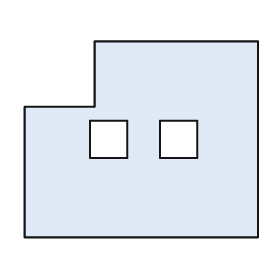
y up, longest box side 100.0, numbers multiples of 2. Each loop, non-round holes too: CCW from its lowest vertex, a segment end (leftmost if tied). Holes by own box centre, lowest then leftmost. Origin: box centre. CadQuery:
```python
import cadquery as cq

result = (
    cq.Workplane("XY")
    .moveTo(-50.0, -42.0)
    .lineTo(50.0, -42.0)
    .lineTo(50.0, 42.0)
    .lineTo(-20.0, 42.0)
    .lineTo(-20.0, 14.0)
    .lineTo(-50.0, 14.0)
    .close()
    .moveTo(-22.0, -8.0)
    .lineTo(-6.0, -8.0)
    .lineTo(-6.0, 8.0)
    .lineTo(-22.0, 8.0)
    .close()
    .moveTo(8.0, -8.0)
    .lineTo(24.0, -8.0)
    .lineTo(24.0, 8.0)
    .lineTo(8.0, 8.0)
    .close()
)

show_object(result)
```